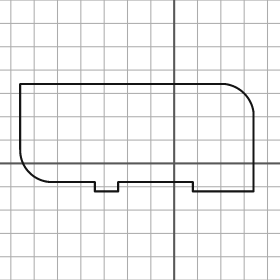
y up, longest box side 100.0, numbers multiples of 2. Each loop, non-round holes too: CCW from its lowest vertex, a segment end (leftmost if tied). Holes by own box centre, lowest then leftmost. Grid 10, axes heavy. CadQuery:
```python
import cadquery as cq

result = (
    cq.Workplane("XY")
    .moveTo(-34.0, -12.0)
    .lineTo(-24.0, -12.0)
    .lineTo(-24.0, -8.0)
    .lineTo(8.0, -8.0)
    .lineTo(8.0, -12.0)
    .lineTo(34.0, -12.0)
    .lineTo(34.0, 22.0)
    .threePointArc((30.0, 30.0), (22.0, 34.0))
    .lineTo(-66.0, 34.0)
    .lineTo(-66.0, 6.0)
    .threePointArc((-62.0, -4.0), (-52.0, -8.0))
    .lineTo(-34.0, -8.0)
    .close()
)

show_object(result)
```